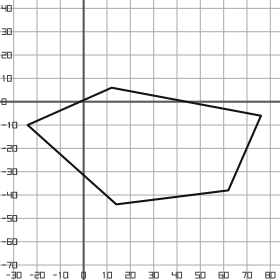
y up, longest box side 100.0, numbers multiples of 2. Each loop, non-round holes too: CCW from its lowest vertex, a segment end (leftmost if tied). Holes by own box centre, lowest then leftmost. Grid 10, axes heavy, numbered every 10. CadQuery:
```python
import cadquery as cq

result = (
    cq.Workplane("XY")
    .moveTo(14.0, -44.0)
    .lineTo(62.0, -38.0)
    .lineTo(76.0, -6.0)
    .lineTo(12.0, 6.0)
    .lineTo(-24.0, -10.0)
    .close()
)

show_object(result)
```